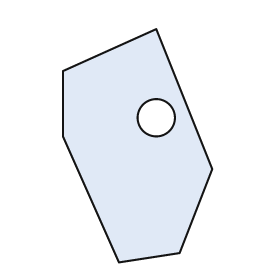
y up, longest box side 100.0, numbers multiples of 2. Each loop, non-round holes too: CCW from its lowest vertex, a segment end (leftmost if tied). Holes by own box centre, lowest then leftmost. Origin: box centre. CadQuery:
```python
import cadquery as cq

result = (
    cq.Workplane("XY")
    .moveTo(-8.0, -50.0)
    .lineTo(18.0, -46.0)
    .lineTo(32.0, -10.0)
    .lineTo(8.0, 50.0)
    .lineTo(-32.0, 32.0)
    .lineTo(-32.0, 4.0)
    .close()
    .moveTo(8.0, 12.0)
    .circle(8.0)
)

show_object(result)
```